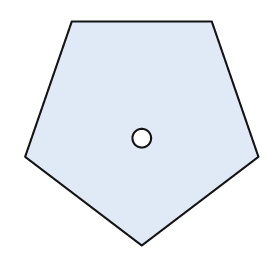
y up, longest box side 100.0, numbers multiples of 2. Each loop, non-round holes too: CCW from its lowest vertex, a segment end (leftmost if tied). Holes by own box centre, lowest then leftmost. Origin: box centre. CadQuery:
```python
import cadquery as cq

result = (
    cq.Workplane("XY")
    .moveTo(0.0, -48.0)
    .lineTo(50.0, -10.0)
    .lineTo(30.0, 48.0)
    .lineTo(-30.0, 48.0)
    .lineTo(-50.0, -10.0)
    .close()
    .moveTo(0.0, -2.0)
    .circle(4.0)
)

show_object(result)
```